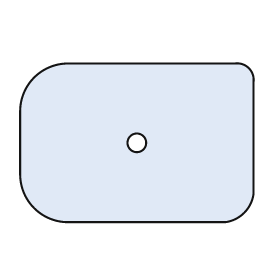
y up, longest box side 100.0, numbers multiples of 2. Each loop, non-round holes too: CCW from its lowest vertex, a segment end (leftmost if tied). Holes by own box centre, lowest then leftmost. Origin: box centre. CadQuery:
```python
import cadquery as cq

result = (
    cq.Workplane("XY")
    .moveTo(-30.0, -34.0)
    .lineTo(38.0, -34.0)
    .threePointArc((46.0, -30.0), (50.0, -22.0))
    .lineTo(50.0, 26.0)
    .threePointArc((48.0, 32.0), (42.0, 34.0))
    .lineTo(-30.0, 34.0)
    .threePointArc((-44.0, 28.0), (-50.0, 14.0))
    .lineTo(-50.0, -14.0)
    .threePointArc((-44.0, -28.0), (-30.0, -34.0))
    .close()
    .moveTo(0.0, 0.0)
    .circle(4.0)
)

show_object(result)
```